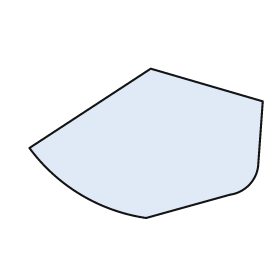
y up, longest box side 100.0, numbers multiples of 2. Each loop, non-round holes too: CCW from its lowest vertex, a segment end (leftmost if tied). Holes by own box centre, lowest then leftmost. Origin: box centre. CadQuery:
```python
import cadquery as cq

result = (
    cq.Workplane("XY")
    .moveTo(0.0, -32.0)
    .lineTo(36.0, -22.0)
    .threePointArc((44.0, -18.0), (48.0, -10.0))
    .lineTo(50.0, 18.0)
    .lineTo(2.0, 32.0)
    .lineTo(-50.0, -2.0)
    .threePointArc((-28.0, -22.0), (0.0, -32.0))
    .close()
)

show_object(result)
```